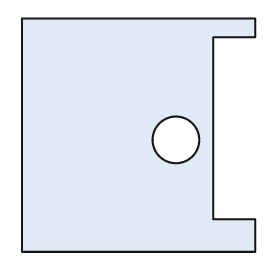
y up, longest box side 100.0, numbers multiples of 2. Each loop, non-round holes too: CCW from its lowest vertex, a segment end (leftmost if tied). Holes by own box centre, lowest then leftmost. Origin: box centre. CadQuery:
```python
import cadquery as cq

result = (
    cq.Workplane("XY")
    .moveTo(-50.0, -50.0)
    .lineTo(50.0, -50.0)
    .lineTo(50.0, -36.0)
    .lineTo(32.0, -36.0)
    .lineTo(32.0, 42.0)
    .lineTo(50.0, 42.0)
    .lineTo(50.0, 50.0)
    .lineTo(-50.0, 50.0)
    .close()
    .moveTo(16.0, -2.0)
    .circle(10.0)
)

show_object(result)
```